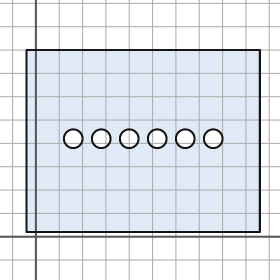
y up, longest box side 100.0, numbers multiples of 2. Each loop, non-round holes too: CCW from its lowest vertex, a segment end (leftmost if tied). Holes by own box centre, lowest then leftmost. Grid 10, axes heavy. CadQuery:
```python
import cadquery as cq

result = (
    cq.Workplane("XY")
    .moveTo(-4.0, 2.0)
    .lineTo(96.0, 2.0)
    .lineTo(96.0, 80.0)
    .lineTo(-4.0, 80.0)
    .close()
    .moveTo(16.0, 42.0)
    .circle(4.0)
    .moveTo(28.0, 42.0)
    .circle(4.0)
    .moveTo(40.0, 42.0)
    .circle(4.0)
    .moveTo(52.0, 42.0)
    .circle(4.0)
    .moveTo(64.0, 42.0)
    .circle(4.0)
    .moveTo(76.0, 42.0)
    .circle(4.0)
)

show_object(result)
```